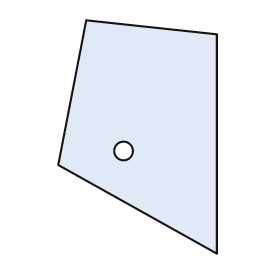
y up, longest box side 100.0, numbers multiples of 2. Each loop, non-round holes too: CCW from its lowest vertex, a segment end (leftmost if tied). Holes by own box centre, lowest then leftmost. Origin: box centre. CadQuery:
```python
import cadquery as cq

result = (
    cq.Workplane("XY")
    .moveTo(34.0, -50.0)
    .lineTo(34.0, 44.0)
    .lineTo(-22.0, 50.0)
    .lineTo(-34.0, -12.0)
    .close()
    .moveTo(-6.0, -6.0)
    .circle(4.0)
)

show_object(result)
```